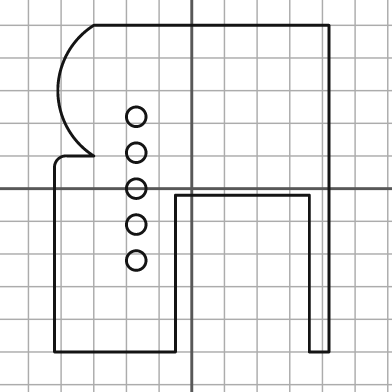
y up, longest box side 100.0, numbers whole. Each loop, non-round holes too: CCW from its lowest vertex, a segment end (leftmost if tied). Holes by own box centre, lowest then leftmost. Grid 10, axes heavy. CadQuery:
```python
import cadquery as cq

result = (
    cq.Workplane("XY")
    .moveTo(-42.0, -50.0)
    .lineTo(-5.0, -50.0)
    .lineTo(-5.0, -2.0)
    .lineTo(36.0, -2.0)
    .lineTo(36.0, -50.0)
    .lineTo(42.0, -50.0)
    .lineTo(42.0, 50.0)
    .lineTo(-30.0, 50.0)
    .threePointArc((-41.0, 30.0), (-30.0, 10.0))
    .lineTo(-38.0, 10.0)
    .threePointArc((-41.0, 9.0), (-42.0, 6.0))
    .close()
    .moveTo(-17.0, -22.0)
    .circle(3.0)
    .moveTo(-17.0, -11.0)
    .circle(3.0)
    .moveTo(-17.0, 0.0)
    .circle(3.0)
    .moveTo(-17.0, 11.0)
    .circle(3.0)
    .moveTo(-17.0, 22.0)
    .circle(3.0)
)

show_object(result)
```